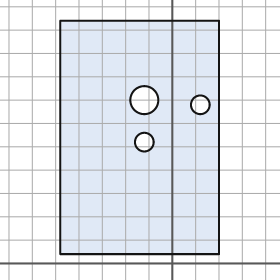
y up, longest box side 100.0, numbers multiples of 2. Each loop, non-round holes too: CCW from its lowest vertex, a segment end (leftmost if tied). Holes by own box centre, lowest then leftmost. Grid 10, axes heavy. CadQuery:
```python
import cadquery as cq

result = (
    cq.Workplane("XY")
    .moveTo(-48.0, 4.0)
    .lineTo(20.0, 4.0)
    .lineTo(20.0, 104.0)
    .lineTo(-48.0, 104.0)
    .close()
    .moveTo(-12.0, 52.0)
    .circle(4.0)
    .moveTo(12.0, 68.0)
    .circle(4.0)
    .moveTo(-12.0, 70.0)
    .circle(6.0)
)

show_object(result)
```